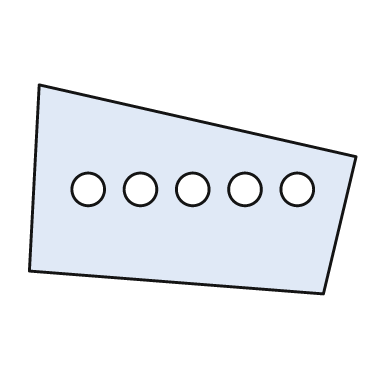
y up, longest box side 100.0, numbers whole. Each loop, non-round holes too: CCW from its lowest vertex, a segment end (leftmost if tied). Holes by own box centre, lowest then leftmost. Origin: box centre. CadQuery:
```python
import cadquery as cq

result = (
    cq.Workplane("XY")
    .moveTo(40.0, -32.0)
    .lineTo(50.0, 10.0)
    .lineTo(-47.0, 32.0)
    .lineTo(-50.0, -25.0)
    .close()
    .moveTo(-32.0, 0.0)
    .circle(5.0)
    .moveTo(-16.0, 0.0)
    .circle(5.0)
    .moveTo(0.0, 0.0)
    .circle(5.0)
    .moveTo(16.0, 0.0)
    .circle(5.0)
    .moveTo(32.0, 0.0)
    .circle(5.0)
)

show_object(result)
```